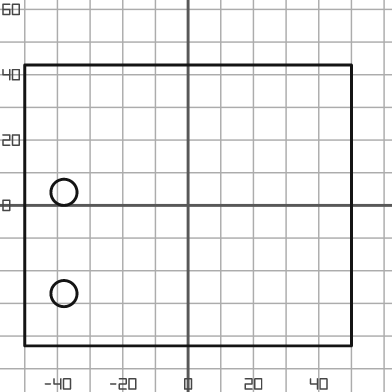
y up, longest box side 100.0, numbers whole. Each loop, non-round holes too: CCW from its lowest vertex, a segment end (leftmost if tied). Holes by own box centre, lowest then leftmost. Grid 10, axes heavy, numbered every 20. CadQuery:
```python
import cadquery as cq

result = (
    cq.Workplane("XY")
    .moveTo(-50.0, -43.0)
    .lineTo(50.0, -43.0)
    .lineTo(50.0, 43.0)
    .lineTo(-50.0, 43.0)
    .close()
    .moveTo(-38.0, -27.0)
    .circle(4.0)
    .moveTo(-38.0, 4.0)
    .circle(4.0)
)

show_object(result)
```